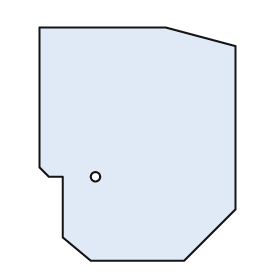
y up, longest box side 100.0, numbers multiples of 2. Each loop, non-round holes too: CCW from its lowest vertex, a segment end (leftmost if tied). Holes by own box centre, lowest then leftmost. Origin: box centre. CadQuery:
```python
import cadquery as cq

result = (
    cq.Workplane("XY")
    .moveTo(-20.0, -50.0)
    .lineTo(20.0, -50.0)
    .lineTo(42.0, -28.0)
    .lineTo(42.0, 42.0)
    .lineTo(12.0, 50.0)
    .lineTo(-42.0, 50.0)
    .lineTo(-42.0, -10.0)
    .lineTo(-38.0, -14.0)
    .lineTo(-32.0, -14.0)
    .lineTo(-32.0, -40.0)
    .close()
    .moveTo(-18.0, -14.0)
    .circle(2.0)
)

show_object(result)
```